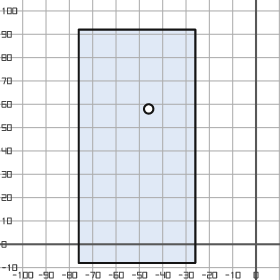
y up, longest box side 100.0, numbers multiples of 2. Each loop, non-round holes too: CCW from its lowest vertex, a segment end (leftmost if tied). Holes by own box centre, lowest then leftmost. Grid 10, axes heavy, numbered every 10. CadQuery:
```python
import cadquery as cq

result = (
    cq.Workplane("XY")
    .moveTo(-76.0, -8.0)
    .lineTo(-26.0, -8.0)
    .lineTo(-26.0, 92.0)
    .lineTo(-76.0, 92.0)
    .close()
    .moveTo(-46.0, 58.0)
    .circle(2.0)
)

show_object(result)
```